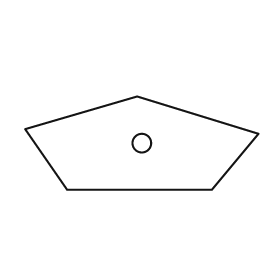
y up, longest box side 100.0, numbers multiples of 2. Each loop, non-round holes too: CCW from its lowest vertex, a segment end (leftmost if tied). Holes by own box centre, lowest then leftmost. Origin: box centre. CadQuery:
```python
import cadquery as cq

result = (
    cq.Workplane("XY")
    .moveTo(-32.0, -20.0)
    .lineTo(30.0, -20.0)
    .lineTo(50.0, 4.0)
    .lineTo(-2.0, 20.0)
    .lineTo(-50.0, 6.0)
    .close()
    .moveTo(0.0, 0.0)
    .circle(4.0)
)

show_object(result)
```